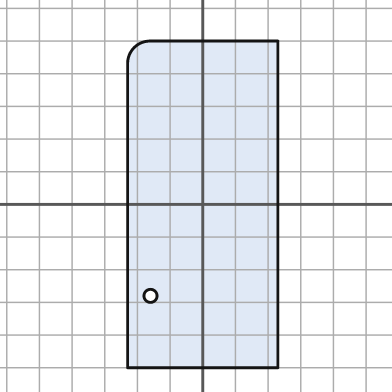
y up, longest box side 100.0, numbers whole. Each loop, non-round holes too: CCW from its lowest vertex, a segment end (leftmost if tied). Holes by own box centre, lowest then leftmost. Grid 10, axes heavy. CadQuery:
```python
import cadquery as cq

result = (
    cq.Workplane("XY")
    .moveTo(-23.0, -50.0)
    .lineTo(23.0, -50.0)
    .lineTo(23.0, 50.0)
    .lineTo(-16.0, 50.0)
    .threePointArc((-21.0, 48.0), (-23.0, 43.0))
    .close()
    .moveTo(-16.0, -28.0)
    .circle(2.0)
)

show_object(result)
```